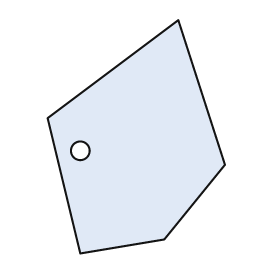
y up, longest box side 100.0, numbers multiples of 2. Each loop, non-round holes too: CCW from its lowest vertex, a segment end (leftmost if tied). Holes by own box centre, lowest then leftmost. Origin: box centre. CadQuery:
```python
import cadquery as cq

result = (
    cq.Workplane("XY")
    .moveTo(-24.0, -50.0)
    .lineTo(12.0, -44.0)
    .lineTo(38.0, -12.0)
    .lineTo(18.0, 50.0)
    .lineTo(-38.0, 8.0)
    .close()
    .moveTo(-24.0, -6.0)
    .circle(4.0)
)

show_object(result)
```